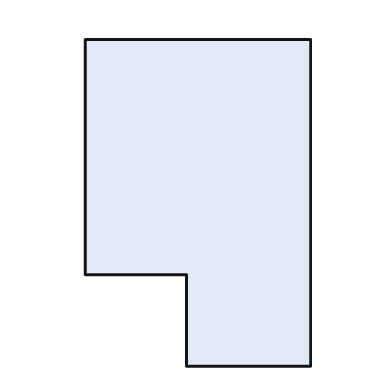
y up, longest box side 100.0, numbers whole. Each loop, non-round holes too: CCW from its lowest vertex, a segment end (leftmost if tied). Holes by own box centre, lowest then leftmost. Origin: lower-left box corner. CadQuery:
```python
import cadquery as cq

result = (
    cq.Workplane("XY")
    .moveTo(31.0, 0.0)
    .lineTo(69.0, 0.0)
    .lineTo(69.0, 100.0)
    .lineTo(0.0, 100.0)
    .lineTo(0.0, 28.0)
    .lineTo(31.0, 28.0)
    .close()
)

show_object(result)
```